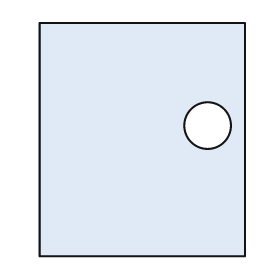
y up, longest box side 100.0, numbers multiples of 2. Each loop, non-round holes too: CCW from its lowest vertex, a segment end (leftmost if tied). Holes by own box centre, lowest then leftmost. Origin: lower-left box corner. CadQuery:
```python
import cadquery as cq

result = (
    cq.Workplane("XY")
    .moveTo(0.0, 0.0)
    .lineTo(88.0, 0.0)
    .lineTo(88.0, 100.0)
    .lineTo(0.0, 100.0)
    .close()
    .moveTo(72.0, 56.0)
    .circle(10.0)
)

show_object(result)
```